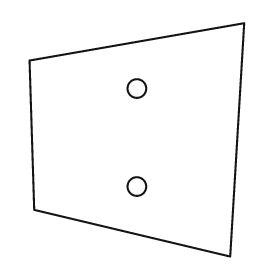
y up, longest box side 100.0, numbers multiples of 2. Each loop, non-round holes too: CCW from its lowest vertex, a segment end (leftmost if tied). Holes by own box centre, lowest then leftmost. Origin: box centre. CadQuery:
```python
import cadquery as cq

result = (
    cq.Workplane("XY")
    .moveTo(40.0, -50.0)
    .lineTo(46.0, 50.0)
    .lineTo(-46.0, 34.0)
    .lineTo(-44.0, -30.0)
    .close()
    .moveTo(0.0, -20.0)
    .circle(4.0)
    .moveTo(0.0, 22.0)
    .circle(4.0)
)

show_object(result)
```